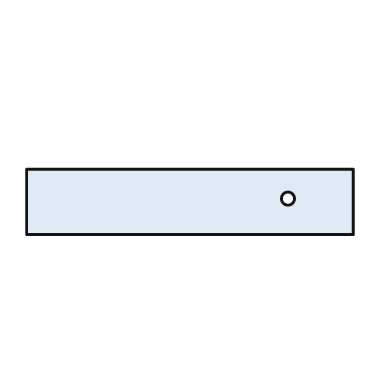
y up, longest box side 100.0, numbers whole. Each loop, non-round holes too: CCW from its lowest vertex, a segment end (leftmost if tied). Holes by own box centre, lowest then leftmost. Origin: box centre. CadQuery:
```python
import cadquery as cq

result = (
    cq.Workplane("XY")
    .moveTo(-50.0, -10.0)
    .lineTo(50.0, -10.0)
    .lineTo(50.0, 10.0)
    .lineTo(-50.0, 10.0)
    .close()
    .moveTo(30.0, 1.0)
    .circle(2.0)
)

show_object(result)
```